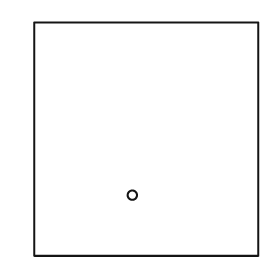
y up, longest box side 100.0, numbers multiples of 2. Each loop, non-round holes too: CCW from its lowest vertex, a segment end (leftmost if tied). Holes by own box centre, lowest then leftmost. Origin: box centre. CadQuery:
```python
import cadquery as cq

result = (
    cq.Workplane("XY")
    .moveTo(-48.0, -50.0)
    .lineTo(48.0, -50.0)
    .lineTo(48.0, 50.0)
    .lineTo(-48.0, 50.0)
    .close()
    .moveTo(-6.0, -24.0)
    .circle(2.0)
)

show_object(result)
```